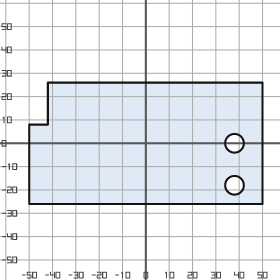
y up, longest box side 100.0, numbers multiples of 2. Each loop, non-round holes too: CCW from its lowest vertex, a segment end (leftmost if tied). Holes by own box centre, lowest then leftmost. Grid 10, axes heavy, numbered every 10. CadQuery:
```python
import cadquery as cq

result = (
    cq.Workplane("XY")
    .moveTo(-50.0, -26.0)
    .lineTo(50.0, -26.0)
    .lineTo(50.0, 26.0)
    .lineTo(-42.0, 26.0)
    .lineTo(-42.0, 8.0)
    .lineTo(-50.0, 8.0)
    .close()
    .moveTo(38.0, -18.0)
    .circle(4.0)
    .moveTo(38.0, 0.0)
    .circle(4.0)
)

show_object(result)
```